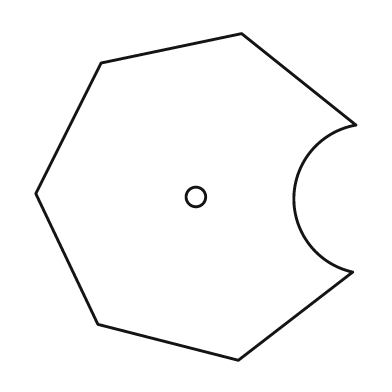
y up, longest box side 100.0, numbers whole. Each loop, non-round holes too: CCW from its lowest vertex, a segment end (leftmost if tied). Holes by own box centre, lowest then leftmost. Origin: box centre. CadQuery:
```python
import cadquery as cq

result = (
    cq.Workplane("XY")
    .moveTo(13.0, -50.0)
    .lineTo(48.0, -23.0)
    .threePointArc((30.0, 0.0), (49.0, 22.0))
    .lineTo(14.0, 50.0)
    .lineTo(-29.0, 41.0)
    .lineTo(-49.0, 1.0)
    .lineTo(-30.0, -39.0)
    .close()
    .moveTo(0.0, 0.0)
    .circle(3.0)
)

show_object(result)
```